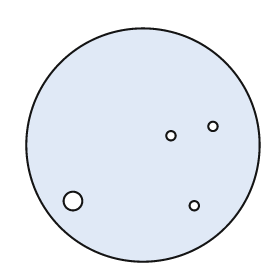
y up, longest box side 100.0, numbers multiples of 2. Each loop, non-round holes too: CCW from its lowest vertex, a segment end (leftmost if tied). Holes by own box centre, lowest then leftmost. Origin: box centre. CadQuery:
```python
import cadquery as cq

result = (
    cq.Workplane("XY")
    .moveTo(0.0, 0.0)
    .circle(50.0)
    .moveTo(22.0, -26.0)
    .circle(2.0)
    .moveTo(-30.0, -24.0)
    .circle(4.0)
    .moveTo(12.0, 4.0)
    .circle(2.0)
    .moveTo(30.0, 8.0)
    .circle(2.0)
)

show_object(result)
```